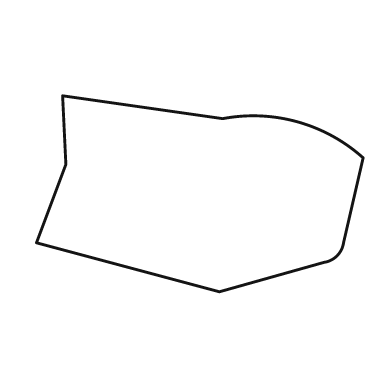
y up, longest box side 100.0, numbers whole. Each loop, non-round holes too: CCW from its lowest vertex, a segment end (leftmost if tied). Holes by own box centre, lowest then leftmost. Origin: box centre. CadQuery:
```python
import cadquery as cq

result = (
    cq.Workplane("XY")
    .moveTo(6.0, -30.0)
    .lineTo(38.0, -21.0)
    .threePointArc((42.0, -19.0), (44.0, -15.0))
    .lineTo(50.0, 11.0)
    .threePointArc((30.0, 22.0), (7.0, 23.0))
    .lineTo(-42.0, 30.0)
    .lineTo(-41.0, 9.0)
    .lineTo(-50.0, -15.0)
    .close()
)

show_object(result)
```